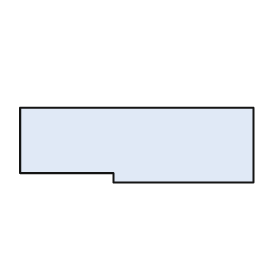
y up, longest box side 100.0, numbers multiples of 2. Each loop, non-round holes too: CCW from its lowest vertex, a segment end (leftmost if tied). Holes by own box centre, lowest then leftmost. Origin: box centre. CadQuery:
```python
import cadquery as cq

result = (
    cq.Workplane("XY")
    .moveTo(-10.0, -16.0)
    .lineTo(50.0, -16.0)
    .lineTo(50.0, 16.0)
    .lineTo(-50.0, 16.0)
    .lineTo(-50.0, -12.0)
    .lineTo(-10.0, -12.0)
    .close()
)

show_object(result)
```